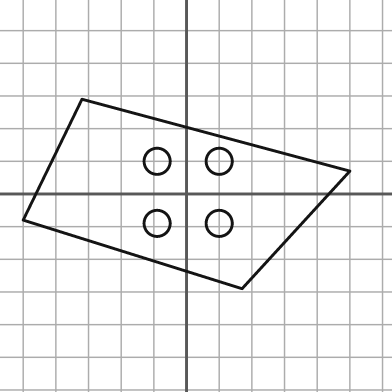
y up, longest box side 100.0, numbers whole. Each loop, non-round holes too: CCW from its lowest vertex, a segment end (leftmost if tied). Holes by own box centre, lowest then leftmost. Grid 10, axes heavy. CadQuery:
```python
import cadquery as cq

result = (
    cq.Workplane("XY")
    .moveTo(17.0, -29.0)
    .lineTo(50.0, 7.0)
    .lineTo(-32.0, 29.0)
    .lineTo(-50.0, -8.0)
    .close()
    .moveTo(-9.0, -9.0)
    .circle(4.0)
    .moveTo(10.0, -9.0)
    .circle(4.0)
    .moveTo(-9.0, 10.0)
    .circle(4.0)
    .moveTo(10.0, 10.0)
    .circle(4.0)
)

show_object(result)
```